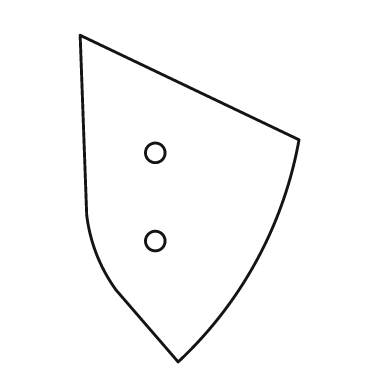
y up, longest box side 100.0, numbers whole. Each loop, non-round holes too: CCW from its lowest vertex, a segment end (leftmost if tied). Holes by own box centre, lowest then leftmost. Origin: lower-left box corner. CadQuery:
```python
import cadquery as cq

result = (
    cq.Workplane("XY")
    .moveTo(30.0, 0.0)
    .threePointArc((54.0, 31.0), (67.0, 68.0))
    .lineTo(0.0, 100.0)
    .lineTo(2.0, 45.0)
    .threePointArc((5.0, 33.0), (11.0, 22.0))
    .close()
    .moveTo(23.0, 37.0)
    .circle(3.0)
    .moveTo(23.0, 64.0)
    .circle(3.0)
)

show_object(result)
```